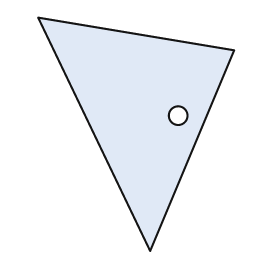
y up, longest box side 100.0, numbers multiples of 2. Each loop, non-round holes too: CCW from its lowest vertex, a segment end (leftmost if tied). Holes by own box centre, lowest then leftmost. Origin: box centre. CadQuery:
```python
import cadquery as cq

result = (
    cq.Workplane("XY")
    .moveTo(6.0, -50.0)
    .lineTo(42.0, 36.0)
    .lineTo(-42.0, 50.0)
    .close()
    .moveTo(18.0, 8.0)
    .circle(4.0)
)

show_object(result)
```